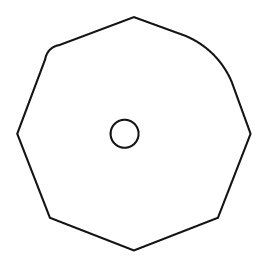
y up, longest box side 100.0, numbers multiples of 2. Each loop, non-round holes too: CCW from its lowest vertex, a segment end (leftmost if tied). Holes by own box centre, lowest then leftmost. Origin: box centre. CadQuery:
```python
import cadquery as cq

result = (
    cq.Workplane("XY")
    .moveTo(0.0, -50.0)
    .lineTo(36.0, -36.0)
    .lineTo(50.0, 0.0)
    .lineTo(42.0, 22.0)
    .threePointArc((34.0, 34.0), (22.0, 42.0))
    .lineTo(0.0, 50.0)
    .lineTo(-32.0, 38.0)
    .threePointArc((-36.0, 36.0), (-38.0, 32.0))
    .lineTo(-50.0, 0.0)
    .lineTo(-36.0, -36.0)
    .close()
    .moveTo(-4.0, 0.0)
    .circle(6.0)
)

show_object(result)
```